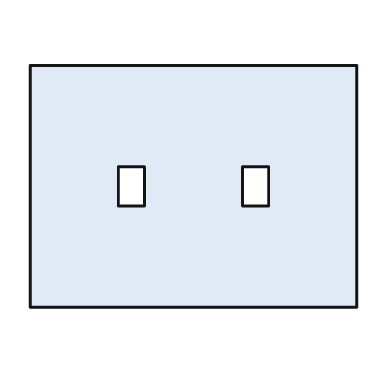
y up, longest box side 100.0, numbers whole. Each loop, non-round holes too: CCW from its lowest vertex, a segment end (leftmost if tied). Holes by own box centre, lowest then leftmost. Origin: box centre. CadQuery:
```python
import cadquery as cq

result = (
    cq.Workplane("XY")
    .moveTo(-50.0, -37.0)
    .lineTo(50.0, -37.0)
    .lineTo(50.0, 37.0)
    .lineTo(-50.0, 37.0)
    .close()
    .moveTo(-23.0, -6.0)
    .lineTo(-15.0, -6.0)
    .lineTo(-15.0, 6.0)
    .lineTo(-23.0, 6.0)
    .close()
    .moveTo(15.0, -6.0)
    .lineTo(23.0, -6.0)
    .lineTo(23.0, 6.0)
    .lineTo(15.0, 6.0)
    .close()
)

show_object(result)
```